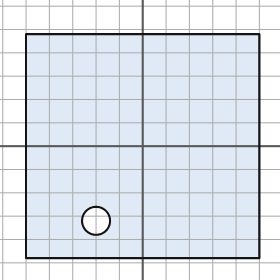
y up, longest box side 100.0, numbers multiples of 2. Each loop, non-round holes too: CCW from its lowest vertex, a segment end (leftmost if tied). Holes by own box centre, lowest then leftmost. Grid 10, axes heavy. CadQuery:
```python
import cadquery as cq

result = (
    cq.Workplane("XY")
    .moveTo(-50.0, -48.0)
    .lineTo(50.0, -48.0)
    .lineTo(50.0, 48.0)
    .lineTo(-50.0, 48.0)
    .close()
    .moveTo(-20.0, -32.0)
    .circle(6.0)
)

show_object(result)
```